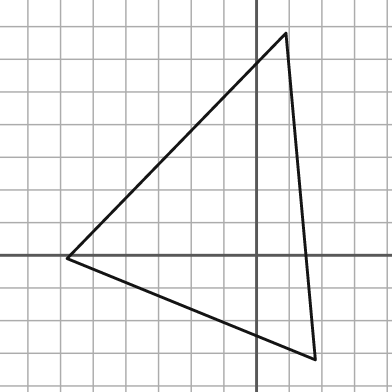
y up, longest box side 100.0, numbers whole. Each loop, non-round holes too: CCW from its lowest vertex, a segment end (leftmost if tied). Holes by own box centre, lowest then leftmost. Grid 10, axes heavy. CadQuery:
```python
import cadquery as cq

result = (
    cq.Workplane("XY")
    .moveTo(18.0, -32.0)
    .lineTo(9.0, 68.0)
    .lineTo(-58.0, -1.0)
    .close()
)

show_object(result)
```